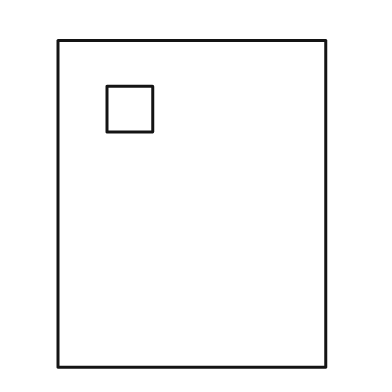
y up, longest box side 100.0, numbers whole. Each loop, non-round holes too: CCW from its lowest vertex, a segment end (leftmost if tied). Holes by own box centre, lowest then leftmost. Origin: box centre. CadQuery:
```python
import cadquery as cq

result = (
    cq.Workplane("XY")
    .moveTo(-41.0, -50.0)
    .lineTo(41.0, -50.0)
    .lineTo(41.0, 50.0)
    .lineTo(-41.0, 50.0)
    .close()
    .moveTo(-26.0, 22.0)
    .lineTo(-12.0, 22.0)
    .lineTo(-12.0, 36.0)
    .lineTo(-26.0, 36.0)
    .close()
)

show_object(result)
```